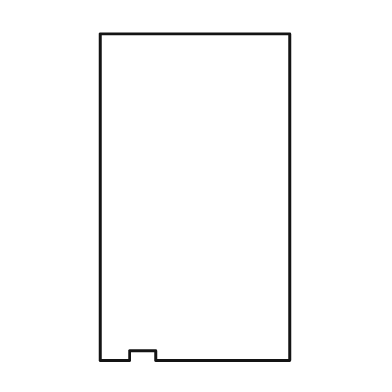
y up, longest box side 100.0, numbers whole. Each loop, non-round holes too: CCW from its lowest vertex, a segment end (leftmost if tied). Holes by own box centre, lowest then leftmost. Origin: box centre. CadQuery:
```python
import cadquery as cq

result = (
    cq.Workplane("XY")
    .moveTo(-29.0, -50.0)
    .lineTo(-20.0, -50.0)
    .lineTo(-20.0, -47.0)
    .lineTo(-12.0, -47.0)
    .lineTo(-12.0, -50.0)
    .lineTo(29.0, -50.0)
    .lineTo(29.0, 50.0)
    .lineTo(-29.0, 50.0)
    .close()
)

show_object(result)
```